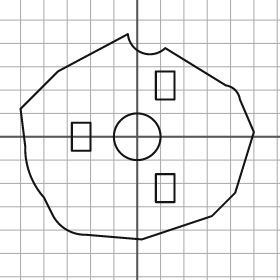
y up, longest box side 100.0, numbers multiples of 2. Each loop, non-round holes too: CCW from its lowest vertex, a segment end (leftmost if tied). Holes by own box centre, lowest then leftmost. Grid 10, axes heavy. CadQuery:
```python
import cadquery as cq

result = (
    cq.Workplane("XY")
    .moveTo(2.0, -44.0)
    .lineTo(32.0, -34.0)
    .lineTo(42.0, -24.0)
    .lineTo(50.0, 2.0)
    .lineTo(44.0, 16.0)
    .threePointArc((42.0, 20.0), (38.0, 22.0))
    .lineTo(12.0, 38.0)
    .threePointArc((2.0, 36.0), (-4.0, 44.0))
    .lineTo(-34.0, 28.0)
    .lineTo(-50.0, 12.0)
    .lineTo(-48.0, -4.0)
    .threePointArc((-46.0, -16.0), (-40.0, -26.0))
    .lineTo(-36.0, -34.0)
    .threePointArc((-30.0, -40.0), (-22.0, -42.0))
    .close()
    .moveTo(8.0, -28.0)
    .lineTo(16.0, -28.0)
    .lineTo(16.0, -16.0)
    .lineTo(8.0, -16.0)
    .close()
    .moveTo(-28.0, -6.0)
    .lineTo(-20.0, -6.0)
    .lineTo(-20.0, 6.0)
    .lineTo(-28.0, 6.0)
    .close()
    .moveTo(0.0, 0.0)
    .circle(10.0)
    .moveTo(8.0, 16.0)
    .lineTo(16.0, 16.0)
    .lineTo(16.0, 28.0)
    .lineTo(8.0, 28.0)
    .close()
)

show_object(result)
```